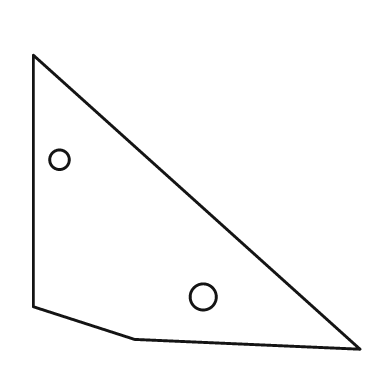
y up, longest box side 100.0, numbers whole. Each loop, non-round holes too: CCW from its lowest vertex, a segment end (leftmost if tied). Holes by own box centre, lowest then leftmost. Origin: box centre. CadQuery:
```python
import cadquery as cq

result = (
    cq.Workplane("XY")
    .moveTo(50.0, -45.0)
    .lineTo(-50.0, 45.0)
    .lineTo(-50.0, -32.0)
    .lineTo(-19.0, -42.0)
    .close()
    .moveTo(2.0, -29.0)
    .circle(4.0)
    .moveTo(-42.0, 13.0)
    .circle(3.0)
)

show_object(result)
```